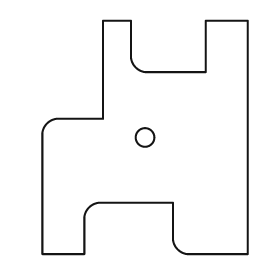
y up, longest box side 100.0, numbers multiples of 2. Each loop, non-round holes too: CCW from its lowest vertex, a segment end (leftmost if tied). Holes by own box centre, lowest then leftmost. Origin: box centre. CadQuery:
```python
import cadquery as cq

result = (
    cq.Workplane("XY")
    .moveTo(-44.0, -50.0)
    .lineTo(-26.0, -50.0)
    .lineTo(-26.0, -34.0)
    .threePointArc((-24.0, -30.0), (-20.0, -28.0))
    .lineTo(12.0, -28.0)
    .lineTo(12.0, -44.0)
    .threePointArc((14.0, -48.0), (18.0, -50.0))
    .lineTo(44.0, -50.0)
    .lineTo(44.0, 50.0)
    .lineTo(26.0, 50.0)
    .lineTo(26.0, 28.0)
    .lineTo(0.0, 28.0)
    .threePointArc((-4.0, 30.0), (-6.0, 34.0))
    .lineTo(-6.0, 50.0)
    .lineTo(-18.0, 50.0)
    .lineTo(-18.0, 8.0)
    .lineTo(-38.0, 8.0)
    .threePointArc((-42.0, 6.0), (-44.0, 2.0))
    .close()
    .moveTo(0.0, 0.0)
    .circle(4.0)
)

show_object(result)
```